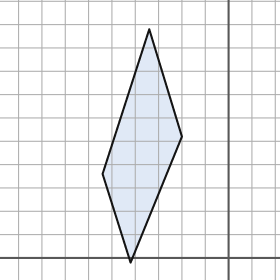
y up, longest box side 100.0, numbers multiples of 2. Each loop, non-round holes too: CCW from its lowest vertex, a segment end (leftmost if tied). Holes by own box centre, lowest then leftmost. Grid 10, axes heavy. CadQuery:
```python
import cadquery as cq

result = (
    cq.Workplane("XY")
    .moveTo(-42.0, -2.0)
    .lineTo(-20.0, 52.0)
    .lineTo(-34.0, 98.0)
    .lineTo(-54.0, 36.0)
    .close()
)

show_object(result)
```